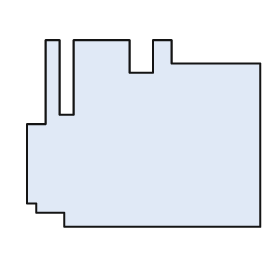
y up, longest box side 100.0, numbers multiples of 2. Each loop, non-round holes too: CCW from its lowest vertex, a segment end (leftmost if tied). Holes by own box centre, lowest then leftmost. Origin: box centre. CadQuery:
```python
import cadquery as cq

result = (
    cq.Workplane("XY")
    .moveTo(-34.0, -40.0)
    .lineTo(50.0, -40.0)
    .lineTo(50.0, 30.0)
    .lineTo(12.0, 30.0)
    .lineTo(12.0, 40.0)
    .lineTo(4.0, 40.0)
    .lineTo(4.0, 26.0)
    .lineTo(-6.0, 26.0)
    .lineTo(-6.0, 40.0)
    .lineTo(-30.0, 40.0)
    .lineTo(-30.0, 8.0)
    .lineTo(-36.0, 8.0)
    .lineTo(-36.0, 40.0)
    .lineTo(-42.0, 40.0)
    .lineTo(-42.0, 4.0)
    .lineTo(-50.0, 4.0)
    .lineTo(-50.0, -30.0)
    .lineTo(-46.0, -30.0)
    .lineTo(-46.0, -34.0)
    .lineTo(-34.0, -34.0)
    .close()
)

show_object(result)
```